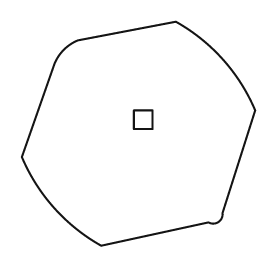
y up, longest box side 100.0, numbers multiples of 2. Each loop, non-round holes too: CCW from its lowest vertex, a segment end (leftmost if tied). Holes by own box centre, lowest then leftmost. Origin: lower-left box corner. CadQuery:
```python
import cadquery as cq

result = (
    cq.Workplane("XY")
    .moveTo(34.0, 0.0)
    .lineTo(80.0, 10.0)
    .threePointArc((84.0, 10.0), (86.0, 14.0))
    .lineTo(100.0, 58.0)
    .threePointArc((86.0, 80.0), (66.0, 96.0))
    .lineTo(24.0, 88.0)
    .threePointArc((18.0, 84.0), (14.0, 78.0))
    .lineTo(0.0, 38.0)
    .threePointArc((14.0, 16.0), (34.0, 0.0))
    .close()
    .moveTo(48.0, 50.0)
    .lineTo(56.0, 50.0)
    .lineTo(56.0, 58.0)
    .lineTo(48.0, 58.0)
    .close()
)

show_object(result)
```